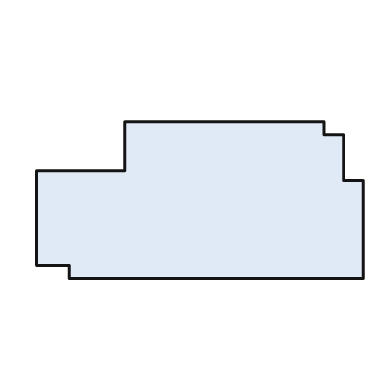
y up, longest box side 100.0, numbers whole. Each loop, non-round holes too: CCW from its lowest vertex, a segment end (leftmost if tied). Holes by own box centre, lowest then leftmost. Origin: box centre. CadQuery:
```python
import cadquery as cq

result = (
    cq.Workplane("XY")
    .moveTo(-40.0, -24.0)
    .lineTo(50.0, -24.0)
    .lineTo(50.0, 6.0)
    .lineTo(44.0, 6.0)
    .lineTo(44.0, 20.0)
    .lineTo(38.0, 20.0)
    .lineTo(38.0, 24.0)
    .lineTo(-23.0, 24.0)
    .lineTo(-23.0, 9.0)
    .lineTo(-50.0, 9.0)
    .lineTo(-50.0, -20.0)
    .lineTo(-40.0, -20.0)
    .close()
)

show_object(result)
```